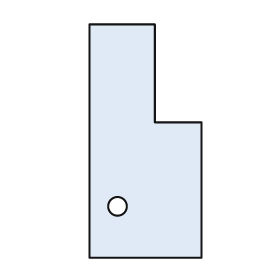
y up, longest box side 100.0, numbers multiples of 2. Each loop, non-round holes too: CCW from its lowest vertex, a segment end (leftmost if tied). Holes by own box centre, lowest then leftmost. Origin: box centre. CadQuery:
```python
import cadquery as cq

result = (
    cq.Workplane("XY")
    .moveTo(-24.0, -50.0)
    .lineTo(24.0, -50.0)
    .lineTo(24.0, 8.0)
    .lineTo(4.0, 8.0)
    .lineTo(4.0, 50.0)
    .lineTo(-24.0, 50.0)
    .close()
    .moveTo(-12.0, -28.0)
    .circle(4.0)
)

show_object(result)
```